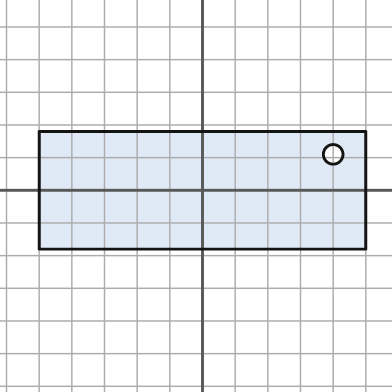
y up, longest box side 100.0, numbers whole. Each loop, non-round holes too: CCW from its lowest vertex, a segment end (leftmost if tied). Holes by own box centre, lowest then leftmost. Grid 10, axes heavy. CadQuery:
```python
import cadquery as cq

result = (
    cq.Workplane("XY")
    .moveTo(-50.0, -18.0)
    .lineTo(50.0, -18.0)
    .lineTo(50.0, 18.0)
    .lineTo(-50.0, 18.0)
    .close()
    .moveTo(40.0, 11.0)
    .circle(3.0)
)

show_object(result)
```